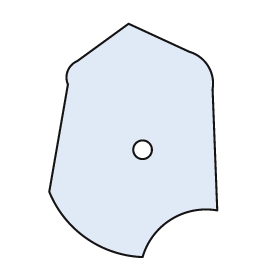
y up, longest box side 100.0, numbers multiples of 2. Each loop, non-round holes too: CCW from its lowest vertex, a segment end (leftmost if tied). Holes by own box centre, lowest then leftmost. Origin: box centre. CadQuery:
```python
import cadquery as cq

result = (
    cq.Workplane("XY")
    .moveTo(4.0, -50.0)
    .threePointArc((16.0, -34.0), (36.0, -30.0))
    .lineTo(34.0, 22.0)
    .threePointArc((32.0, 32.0), (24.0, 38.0))
    .lineTo(-2.0, 50.0)
    .lineTo(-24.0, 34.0)
    .threePointArc((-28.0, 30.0), (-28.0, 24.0))
    .lineTo(-36.0, -22.0)
    .threePointArc((-20.0, -42.0), (4.0, -50.0))
    .close()
    .moveTo(4.0, -4.0)
    .circle(4.0)
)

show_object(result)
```